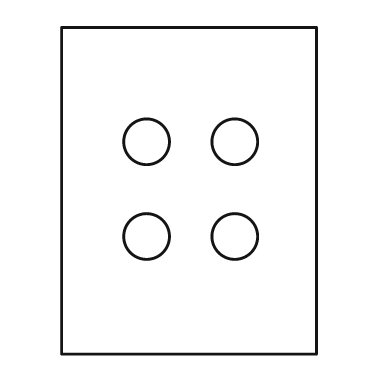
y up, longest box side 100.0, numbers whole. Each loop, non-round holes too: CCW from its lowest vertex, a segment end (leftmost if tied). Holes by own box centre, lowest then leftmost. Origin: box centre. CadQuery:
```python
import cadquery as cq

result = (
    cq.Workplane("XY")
    .moveTo(-39.0, -50.0)
    .lineTo(39.0, -50.0)
    .lineTo(39.0, 50.0)
    .lineTo(-39.0, 50.0)
    .close()
    .moveTo(-13.0, -14.0)
    .circle(7.0)
    .moveTo(14.0, -14.0)
    .circle(7.0)
    .moveTo(-13.0, 15.0)
    .circle(7.0)
    .moveTo(14.0, 15.0)
    .circle(7.0)
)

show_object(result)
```